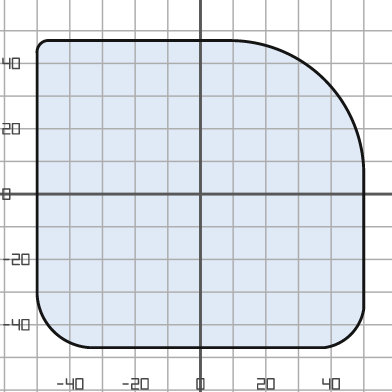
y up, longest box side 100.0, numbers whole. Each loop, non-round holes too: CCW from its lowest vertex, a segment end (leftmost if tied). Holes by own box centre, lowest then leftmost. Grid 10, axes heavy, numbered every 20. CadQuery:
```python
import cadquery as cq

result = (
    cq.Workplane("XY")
    .moveTo(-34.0, -47.0)
    .lineTo(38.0, -47.0)
    .threePointArc((46.0, -43.0), (50.0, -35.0))
    .lineTo(50.0, 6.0)
    .threePointArc((38.0, 35.0), (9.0, 47.0))
    .lineTo(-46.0, 47.0)
    .threePointArc((-49.0, 46.0), (-50.0, 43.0))
    .lineTo(-50.0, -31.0)
    .threePointArc((-45.0, -42.0), (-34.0, -47.0))
    .close()
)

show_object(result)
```